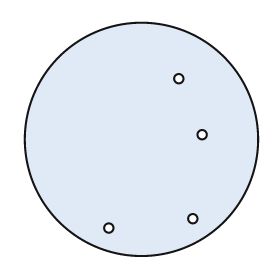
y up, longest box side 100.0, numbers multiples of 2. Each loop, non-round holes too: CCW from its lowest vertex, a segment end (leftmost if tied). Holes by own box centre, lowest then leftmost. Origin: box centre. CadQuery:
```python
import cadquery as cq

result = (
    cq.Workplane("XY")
    .moveTo(0.0, 0.0)
    .circle(50.0)
    .moveTo(-14.0, -38.0)
    .circle(2.0)
    .moveTo(22.0, -34.0)
    .circle(2.0)
    .moveTo(26.0, 2.0)
    .circle(2.0)
    .moveTo(16.0, 26.0)
    .circle(2.0)
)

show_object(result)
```